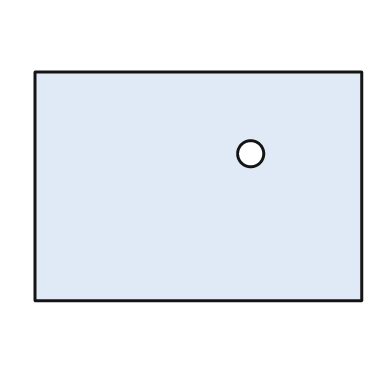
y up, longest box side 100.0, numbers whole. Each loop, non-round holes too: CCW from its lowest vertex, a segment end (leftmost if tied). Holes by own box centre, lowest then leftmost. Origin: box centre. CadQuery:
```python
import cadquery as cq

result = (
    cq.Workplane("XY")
    .moveTo(-50.0, -35.0)
    .lineTo(50.0, -35.0)
    .lineTo(50.0, 35.0)
    .lineTo(-50.0, 35.0)
    .close()
    .moveTo(16.0, 10.0)
    .circle(4.0)
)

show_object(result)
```